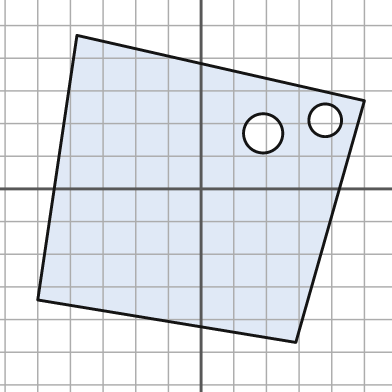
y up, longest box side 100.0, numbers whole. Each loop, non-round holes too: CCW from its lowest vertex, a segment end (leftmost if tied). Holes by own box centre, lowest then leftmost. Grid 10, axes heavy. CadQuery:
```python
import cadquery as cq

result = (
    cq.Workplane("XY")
    .moveTo(29.0, -47.0)
    .lineTo(50.0, 27.0)
    .lineTo(-38.0, 47.0)
    .lineTo(-50.0, -34.0)
    .close()
    .moveTo(19.0, 17.0)
    .circle(6.0)
    .moveTo(38.0, 21.0)
    .circle(5.0)
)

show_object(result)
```